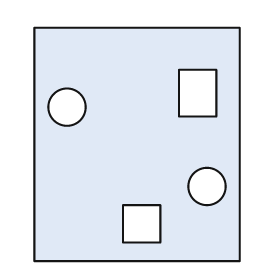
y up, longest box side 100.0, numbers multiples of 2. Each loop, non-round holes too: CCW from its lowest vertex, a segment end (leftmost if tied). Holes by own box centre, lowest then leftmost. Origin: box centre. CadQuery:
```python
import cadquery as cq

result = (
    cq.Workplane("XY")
    .moveTo(-44.0, -50.0)
    .lineTo(44.0, -50.0)
    .lineTo(44.0, 50.0)
    .lineTo(-44.0, 50.0)
    .close()
    .moveTo(-6.0, -42.0)
    .lineTo(10.0, -42.0)
    .lineTo(10.0, -26.0)
    .lineTo(-6.0, -26.0)
    .close()
    .moveTo(30.0, -18.0)
    .circle(8.0)
    .moveTo(-30.0, 16.0)
    .circle(8.0)
    .moveTo(18.0, 12.0)
    .lineTo(34.0, 12.0)
    .lineTo(34.0, 32.0)
    .lineTo(18.0, 32.0)
    .close()
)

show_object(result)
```